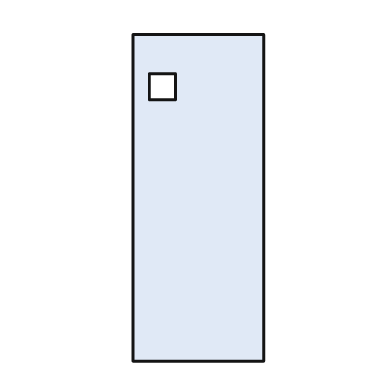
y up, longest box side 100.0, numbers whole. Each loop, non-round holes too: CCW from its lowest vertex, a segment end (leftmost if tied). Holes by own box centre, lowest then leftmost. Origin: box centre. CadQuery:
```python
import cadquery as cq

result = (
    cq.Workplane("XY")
    .moveTo(-20.0, -50.0)
    .lineTo(20.0, -50.0)
    .lineTo(20.0, 50.0)
    .lineTo(-20.0, 50.0)
    .close()
    .moveTo(-15.0, 30.0)
    .lineTo(-7.0, 30.0)
    .lineTo(-7.0, 38.0)
    .lineTo(-15.0, 38.0)
    .close()
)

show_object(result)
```